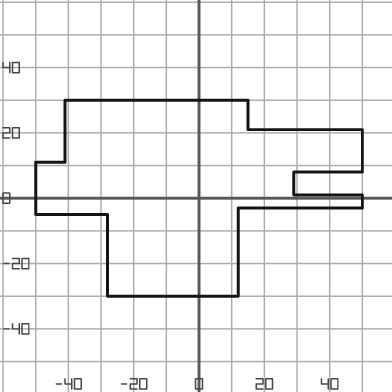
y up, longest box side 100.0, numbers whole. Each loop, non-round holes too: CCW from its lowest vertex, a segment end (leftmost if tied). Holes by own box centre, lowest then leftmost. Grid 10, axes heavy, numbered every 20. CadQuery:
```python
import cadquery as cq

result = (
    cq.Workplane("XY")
    .moveTo(-28.0, -30.0)
    .lineTo(12.0, -30.0)
    .lineTo(12.0, -3.0)
    .lineTo(50.0, -3.0)
    .lineTo(50.0, 1.0)
    .lineTo(29.0, 1.0)
    .lineTo(29.0, 8.0)
    .lineTo(50.0, 8.0)
    .lineTo(50.0, 21.0)
    .lineTo(15.0, 21.0)
    .lineTo(15.0, 30.0)
    .lineTo(-41.0, 30.0)
    .lineTo(-41.0, 11.0)
    .lineTo(-50.0, 11.0)
    .lineTo(-50.0, -5.0)
    .lineTo(-28.0, -5.0)
    .close()
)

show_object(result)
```